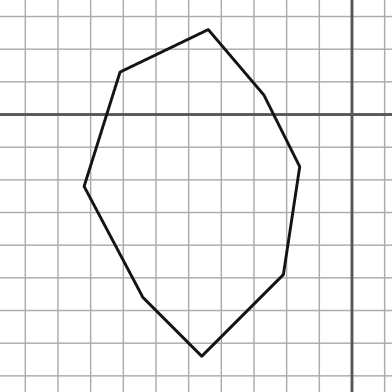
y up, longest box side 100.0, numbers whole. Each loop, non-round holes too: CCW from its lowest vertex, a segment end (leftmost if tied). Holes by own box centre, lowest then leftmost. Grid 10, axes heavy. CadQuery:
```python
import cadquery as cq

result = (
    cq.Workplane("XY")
    .moveTo(-46.0, -74.0)
    .lineTo(-21.0, -49.0)
    .lineTo(-16.0, -16.0)
    .lineTo(-27.0, 6.0)
    .lineTo(-44.0, 26.0)
    .lineTo(-71.0, 13.0)
    .lineTo(-82.0, -22.0)
    .lineTo(-64.0, -56.0)
    .close()
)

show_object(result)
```